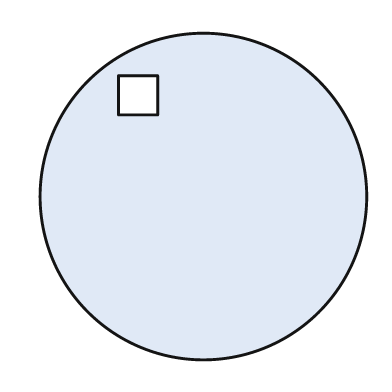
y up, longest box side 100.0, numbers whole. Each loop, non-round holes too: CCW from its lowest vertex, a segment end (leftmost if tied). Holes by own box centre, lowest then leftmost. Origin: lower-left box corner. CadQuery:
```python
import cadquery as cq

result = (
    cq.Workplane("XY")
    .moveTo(50.0, 50.0)
    .circle(50.0)
    .moveTo(24.0, 75.0)
    .lineTo(36.0, 75.0)
    .lineTo(36.0, 87.0)
    .lineTo(24.0, 87.0)
    .close()
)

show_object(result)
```